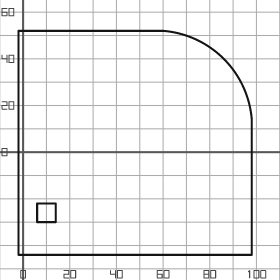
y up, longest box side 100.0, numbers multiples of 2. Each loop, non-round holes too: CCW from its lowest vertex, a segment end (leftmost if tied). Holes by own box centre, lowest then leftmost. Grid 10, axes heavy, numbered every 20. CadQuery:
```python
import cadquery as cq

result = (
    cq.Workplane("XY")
    .moveTo(-2.0, -44.0)
    .lineTo(98.0, -44.0)
    .lineTo(98.0, 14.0)
    .threePointArc((86.0, 40.0), (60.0, 52.0))
    .lineTo(-2.0, 52.0)
    .close()
    .moveTo(6.0, -30.0)
    .lineTo(14.0, -30.0)
    .lineTo(14.0, -22.0)
    .lineTo(6.0, -22.0)
    .close()
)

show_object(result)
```